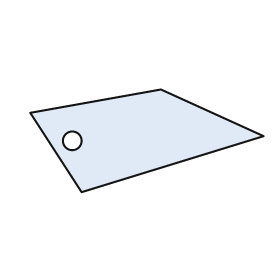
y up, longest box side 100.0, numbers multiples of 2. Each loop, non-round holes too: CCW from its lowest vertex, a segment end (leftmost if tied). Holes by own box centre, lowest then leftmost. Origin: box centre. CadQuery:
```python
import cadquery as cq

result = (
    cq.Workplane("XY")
    .moveTo(-28.0, -22.0)
    .lineTo(50.0, 2.0)
    .lineTo(6.0, 22.0)
    .lineTo(-50.0, 12.0)
    .close()
    .moveTo(-32.0, 0.0)
    .circle(4.0)
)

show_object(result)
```